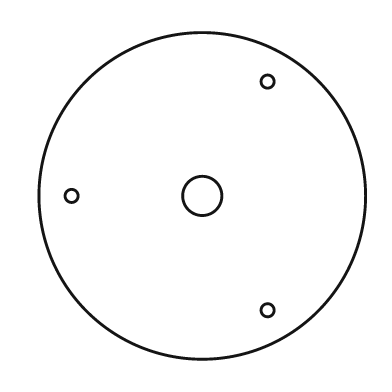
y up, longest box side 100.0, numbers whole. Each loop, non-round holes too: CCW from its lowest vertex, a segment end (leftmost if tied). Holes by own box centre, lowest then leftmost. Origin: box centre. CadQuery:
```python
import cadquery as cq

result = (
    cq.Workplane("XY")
    .moveTo(0.0, 0.0)
    .circle(50.0)
    .moveTo(20.0, -35.0)
    .circle(2.0)
    .moveTo(-40.0, 0.0)
    .circle(2.0)
    .moveTo(0.0, 0.0)
    .circle(6.0)
    .moveTo(20.0, 35.0)
    .circle(2.0)
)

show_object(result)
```